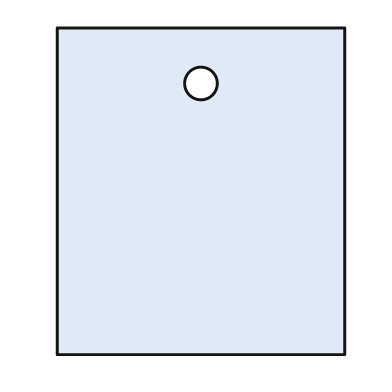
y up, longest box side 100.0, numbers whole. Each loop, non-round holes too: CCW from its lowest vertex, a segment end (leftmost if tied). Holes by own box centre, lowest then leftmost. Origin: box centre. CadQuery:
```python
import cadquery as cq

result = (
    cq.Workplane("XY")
    .moveTo(-44.0, -50.0)
    .lineTo(44.0, -50.0)
    .lineTo(44.0, 50.0)
    .lineTo(-44.0, 50.0)
    .close()
    .moveTo(0.0, 33.0)
    .circle(5.0)
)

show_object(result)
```